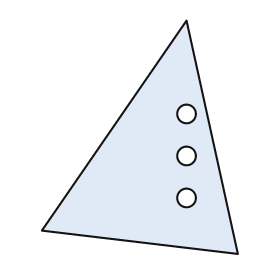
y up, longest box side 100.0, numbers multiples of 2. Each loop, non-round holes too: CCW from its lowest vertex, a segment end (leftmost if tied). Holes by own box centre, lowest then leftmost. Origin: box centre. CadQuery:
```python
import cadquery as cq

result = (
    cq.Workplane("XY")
    .moveTo(42.0, -50.0)
    .lineTo(20.0, 50.0)
    .lineTo(-42.0, -40.0)
    .close()
    .moveTo(20.0, -26.0)
    .circle(4.0)
    .moveTo(20.0, -8.0)
    .circle(4.0)
    .moveTo(20.0, 10.0)
    .circle(4.0)
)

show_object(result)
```